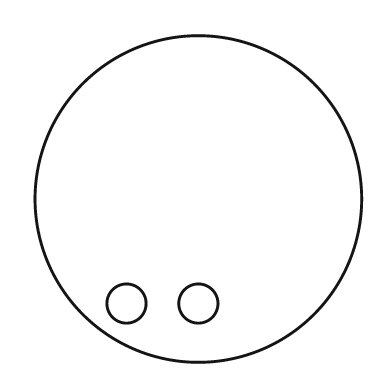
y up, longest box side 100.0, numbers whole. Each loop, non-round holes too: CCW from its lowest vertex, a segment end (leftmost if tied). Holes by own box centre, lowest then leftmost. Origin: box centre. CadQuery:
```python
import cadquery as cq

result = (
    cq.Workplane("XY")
    .moveTo(0.0, 0.0)
    .circle(50.0)
    .moveTo(-22.0, -32.0)
    .circle(6.0)
    .moveTo(0.0, -32.0)
    .circle(6.0)
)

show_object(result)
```